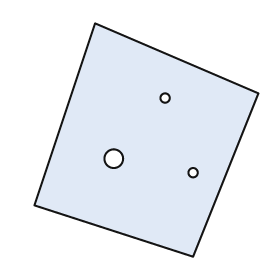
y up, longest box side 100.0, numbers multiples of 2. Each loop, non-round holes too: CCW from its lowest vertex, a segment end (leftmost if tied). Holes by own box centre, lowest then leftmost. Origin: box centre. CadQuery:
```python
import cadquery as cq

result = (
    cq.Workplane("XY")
    .moveTo(20.0, -50.0)
    .lineTo(48.0, 20.0)
    .lineTo(-22.0, 50.0)
    .lineTo(-48.0, -28.0)
    .close()
    .moveTo(20.0, -14.0)
    .circle(2.0)
    .moveTo(-14.0, -8.0)
    .circle(4.0)
    .moveTo(8.0, 18.0)
    .circle(2.0)
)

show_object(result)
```